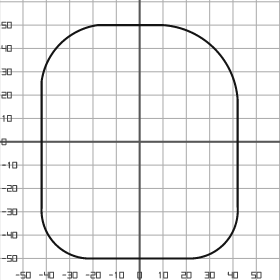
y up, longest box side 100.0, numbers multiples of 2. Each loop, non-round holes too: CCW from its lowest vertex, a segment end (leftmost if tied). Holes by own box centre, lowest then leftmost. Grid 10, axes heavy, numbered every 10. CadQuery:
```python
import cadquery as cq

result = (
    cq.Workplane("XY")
    .moveTo(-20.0, -50.0)
    .lineTo(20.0, -50.0)
    .threePointArc((36.0, -44.0), (42.0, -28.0))
    .lineTo(42.0, 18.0)
    .threePointArc((32.0, 40.0), (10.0, 50.0))
    .lineTo(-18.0, 50.0)
    .threePointArc((-34.0, 42.0), (-42.0, 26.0))
    .lineTo(-42.0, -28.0)
    .threePointArc((-36.0, -44.0), (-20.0, -50.0))
    .close()
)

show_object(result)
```